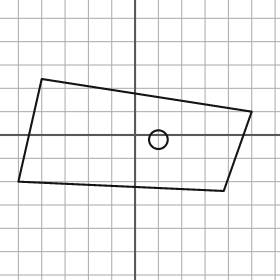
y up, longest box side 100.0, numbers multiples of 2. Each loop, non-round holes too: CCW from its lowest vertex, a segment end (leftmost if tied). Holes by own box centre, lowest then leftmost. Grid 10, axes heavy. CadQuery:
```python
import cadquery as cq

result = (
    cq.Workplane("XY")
    .moveTo(38.0, -24.0)
    .lineTo(50.0, 10.0)
    .lineTo(-40.0, 24.0)
    .lineTo(-50.0, -20.0)
    .close()
    .moveTo(10.0, -2.0)
    .circle(4.0)
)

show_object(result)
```